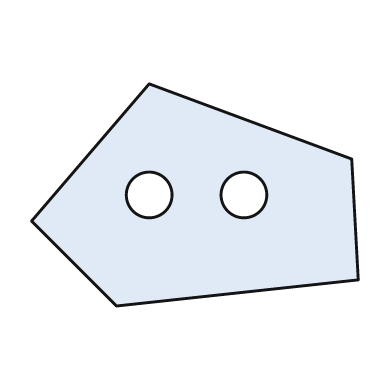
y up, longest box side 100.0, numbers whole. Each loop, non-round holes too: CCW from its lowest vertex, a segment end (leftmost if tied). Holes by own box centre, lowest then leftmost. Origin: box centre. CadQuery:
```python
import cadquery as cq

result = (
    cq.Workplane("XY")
    .moveTo(-24.0, -34.0)
    .lineTo(50.0, -26.0)
    .lineTo(48.0, 11.0)
    .lineTo(-14.0, 34.0)
    .lineTo(-50.0, -8.0)
    .close()
    .moveTo(-14.0, 0.0)
    .circle(7.0)
    .moveTo(15.0, 0.0)
    .circle(7.0)
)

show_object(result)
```